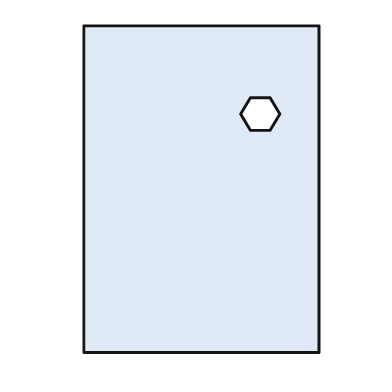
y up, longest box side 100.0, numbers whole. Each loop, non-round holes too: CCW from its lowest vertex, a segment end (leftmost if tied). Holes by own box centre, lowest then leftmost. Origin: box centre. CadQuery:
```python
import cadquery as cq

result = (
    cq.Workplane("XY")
    .moveTo(-36.0, -50.0)
    .lineTo(36.0, -50.0)
    .lineTo(36.0, 50.0)
    .lineTo(-36.0, 50.0)
    .close()
    .moveTo(15.0, 18.0)
    .lineTo(21.0, 18.0)
    .lineTo(24.0, 23.0)
    .lineTo(21.0, 28.0)
    .lineTo(15.0, 28.0)
    .lineTo(12.0, 23.0)
    .close()
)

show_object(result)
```